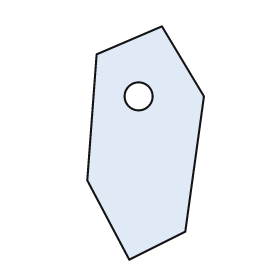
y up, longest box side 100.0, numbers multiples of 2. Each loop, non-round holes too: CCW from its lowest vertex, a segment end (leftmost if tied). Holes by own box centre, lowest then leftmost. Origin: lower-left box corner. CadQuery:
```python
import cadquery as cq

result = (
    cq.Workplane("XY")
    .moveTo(18.0, 0.0)
    .lineTo(42.0, 12.0)
    .lineTo(50.0, 70.0)
    .lineTo(32.0, 100.0)
    .lineTo(4.0, 88.0)
    .lineTo(0.0, 34.0)
    .close()
    .moveTo(22.0, 70.0)
    .circle(6.0)
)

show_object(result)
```